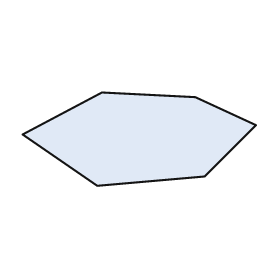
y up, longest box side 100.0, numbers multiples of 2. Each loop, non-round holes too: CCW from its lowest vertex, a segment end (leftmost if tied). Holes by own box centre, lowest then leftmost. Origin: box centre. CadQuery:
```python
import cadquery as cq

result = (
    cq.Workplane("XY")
    .moveTo(-18.0, -20.0)
    .lineTo(28.0, -16.0)
    .lineTo(50.0, 6.0)
    .lineTo(24.0, 18.0)
    .lineTo(-16.0, 20.0)
    .lineTo(-50.0, 2.0)
    .close()
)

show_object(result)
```